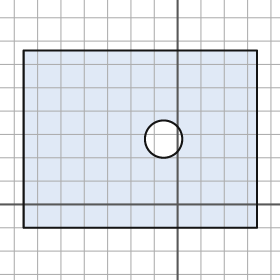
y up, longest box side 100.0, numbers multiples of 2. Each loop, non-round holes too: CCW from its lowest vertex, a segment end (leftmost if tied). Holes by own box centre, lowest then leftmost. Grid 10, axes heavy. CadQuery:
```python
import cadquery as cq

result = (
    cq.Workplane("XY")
    .moveTo(-66.0, -10.0)
    .lineTo(34.0, -10.0)
    .lineTo(34.0, 66.0)
    .lineTo(-66.0, 66.0)
    .close()
    .moveTo(-6.0, 28.0)
    .circle(8.0)
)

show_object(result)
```